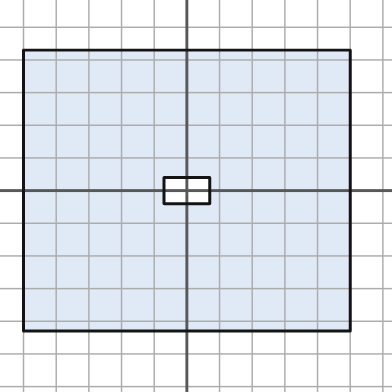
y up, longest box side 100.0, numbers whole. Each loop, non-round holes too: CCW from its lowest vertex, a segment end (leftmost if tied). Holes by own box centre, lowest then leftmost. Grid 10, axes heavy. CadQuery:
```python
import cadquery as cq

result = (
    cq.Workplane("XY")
    .moveTo(-50.0, -43.0)
    .lineTo(50.0, -43.0)
    .lineTo(50.0, 43.0)
    .lineTo(-50.0, 43.0)
    .close()
    .moveTo(-7.0, -4.0)
    .lineTo(7.0, -4.0)
    .lineTo(7.0, 4.0)
    .lineTo(-7.0, 4.0)
    .close()
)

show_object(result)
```